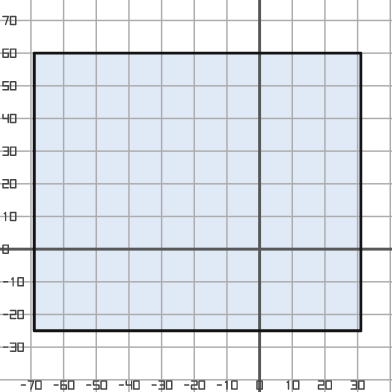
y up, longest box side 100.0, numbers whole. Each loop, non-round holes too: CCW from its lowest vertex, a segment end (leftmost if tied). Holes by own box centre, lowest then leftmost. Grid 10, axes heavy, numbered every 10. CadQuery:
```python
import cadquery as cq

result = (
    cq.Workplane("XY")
    .moveTo(-69.0, -25.0)
    .lineTo(31.0, -25.0)
    .lineTo(31.0, 60.0)
    .lineTo(-69.0, 60.0)
    .close()
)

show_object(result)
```